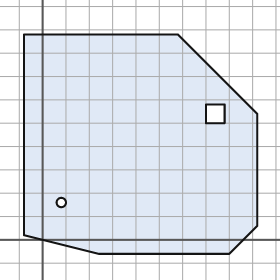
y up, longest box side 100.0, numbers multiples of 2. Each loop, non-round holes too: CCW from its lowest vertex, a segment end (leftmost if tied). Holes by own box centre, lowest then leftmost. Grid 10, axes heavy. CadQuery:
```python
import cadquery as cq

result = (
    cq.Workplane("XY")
    .moveTo(24.0, -6.0)
    .lineTo(80.0, -6.0)
    .lineTo(92.0, 6.0)
    .lineTo(92.0, 54.0)
    .lineTo(58.0, 88.0)
    .lineTo(-8.0, 88.0)
    .lineTo(-8.0, 2.0)
    .close()
    .moveTo(8.0, 16.0)
    .circle(2.0)
    .moveTo(70.0, 50.0)
    .lineTo(78.0, 50.0)
    .lineTo(78.0, 58.0)
    .lineTo(70.0, 58.0)
    .close()
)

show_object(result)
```